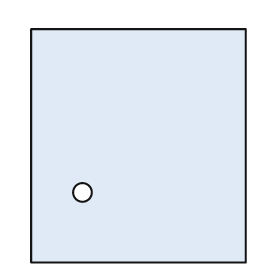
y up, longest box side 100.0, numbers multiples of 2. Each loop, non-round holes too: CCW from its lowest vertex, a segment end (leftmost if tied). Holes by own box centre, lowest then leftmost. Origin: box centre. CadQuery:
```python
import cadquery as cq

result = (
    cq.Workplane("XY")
    .moveTo(-46.0, -50.0)
    .lineTo(46.0, -50.0)
    .lineTo(46.0, 50.0)
    .lineTo(-46.0, 50.0)
    .close()
    .moveTo(-24.0, -20.0)
    .circle(4.0)
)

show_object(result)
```